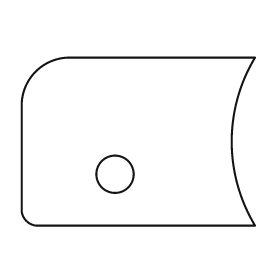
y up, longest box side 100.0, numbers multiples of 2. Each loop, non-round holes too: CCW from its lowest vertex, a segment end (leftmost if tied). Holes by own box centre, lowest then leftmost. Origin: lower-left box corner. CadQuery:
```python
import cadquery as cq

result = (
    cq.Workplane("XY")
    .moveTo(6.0, 0.0)
    .lineTo(100.0, 0.0)
    .threePointArc((90.0, 36.0), (100.0, 72.0))
    .lineTo(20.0, 72.0)
    .threePointArc((6.0, 66.0), (0.0, 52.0))
    .lineTo(0.0, 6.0)
    .threePointArc((2.0, 2.0), (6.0, 0.0))
    .close()
    .moveTo(40.0, 22.0)
    .circle(8.0)
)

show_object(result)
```